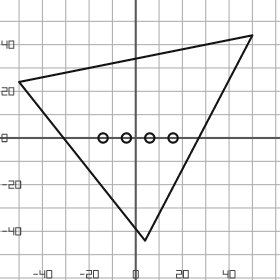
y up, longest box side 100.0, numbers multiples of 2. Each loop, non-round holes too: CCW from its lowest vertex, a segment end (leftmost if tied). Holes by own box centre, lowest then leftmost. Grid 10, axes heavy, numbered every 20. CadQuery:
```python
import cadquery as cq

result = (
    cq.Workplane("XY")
    .moveTo(4.0, -44.0)
    .lineTo(50.0, 44.0)
    .lineTo(-50.0, 24.0)
    .close()
    .moveTo(-14.0, 0.0)
    .circle(2.0)
    .moveTo(-4.0, 0.0)
    .circle(2.0)
    .moveTo(6.0, 0.0)
    .circle(2.0)
    .moveTo(16.0, 0.0)
    .circle(2.0)
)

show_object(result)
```